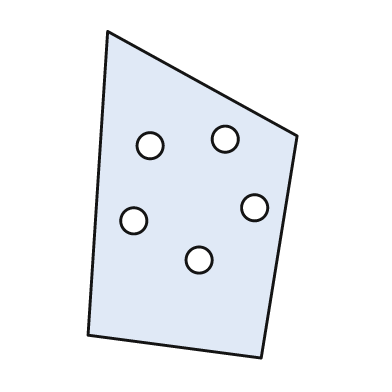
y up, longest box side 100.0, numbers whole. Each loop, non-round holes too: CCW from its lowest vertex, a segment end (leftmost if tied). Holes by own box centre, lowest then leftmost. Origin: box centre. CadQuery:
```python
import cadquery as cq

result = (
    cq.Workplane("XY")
    .moveTo(21.0, -50.0)
    .lineTo(32.0, 18.0)
    .lineTo(-26.0, 50.0)
    .lineTo(-32.0, -43.0)
    .close()
    .moveTo(2.0, -20.0)
    .circle(4.0)
    .moveTo(-18.0, -8.0)
    .circle(4.0)
    .moveTo(19.0, -4.0)
    .circle(4.0)
    .moveTo(-13.0, 15.0)
    .circle(4.0)
    .moveTo(10.0, 17.0)
    .circle(4.0)
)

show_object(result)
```